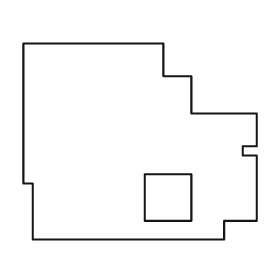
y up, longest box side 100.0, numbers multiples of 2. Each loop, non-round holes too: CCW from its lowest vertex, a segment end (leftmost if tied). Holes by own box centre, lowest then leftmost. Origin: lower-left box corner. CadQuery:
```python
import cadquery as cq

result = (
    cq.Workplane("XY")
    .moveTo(4.0, 0.0)
    .lineTo(86.0, 0.0)
    .lineTo(86.0, 8.0)
    .lineTo(100.0, 8.0)
    .lineTo(100.0, 36.0)
    .lineTo(94.0, 36.0)
    .lineTo(94.0, 40.0)
    .lineTo(100.0, 40.0)
    .lineTo(100.0, 54.0)
    .lineTo(72.0, 54.0)
    .lineTo(72.0, 70.0)
    .lineTo(60.0, 70.0)
    .lineTo(60.0, 84.0)
    .lineTo(0.0, 84.0)
    .lineTo(0.0, 24.0)
    .lineTo(4.0, 24.0)
    .close()
    .moveTo(52.0, 8.0)
    .lineTo(72.0, 8.0)
    .lineTo(72.0, 28.0)
    .lineTo(52.0, 28.0)
    .close()
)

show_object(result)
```